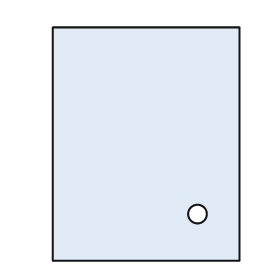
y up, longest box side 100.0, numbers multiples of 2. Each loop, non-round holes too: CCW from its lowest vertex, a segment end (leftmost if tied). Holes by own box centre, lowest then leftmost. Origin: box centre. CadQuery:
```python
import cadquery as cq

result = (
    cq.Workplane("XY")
    .moveTo(-40.0, -50.0)
    .lineTo(40.0, -50.0)
    .lineTo(40.0, 50.0)
    .lineTo(-40.0, 50.0)
    .close()
    .moveTo(22.0, -30.0)
    .circle(4.0)
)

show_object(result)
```